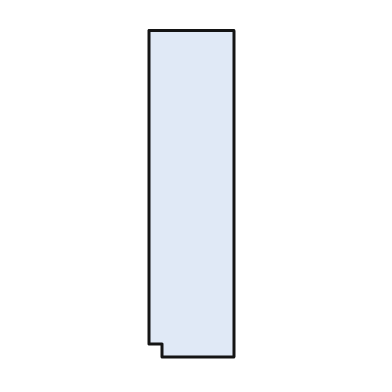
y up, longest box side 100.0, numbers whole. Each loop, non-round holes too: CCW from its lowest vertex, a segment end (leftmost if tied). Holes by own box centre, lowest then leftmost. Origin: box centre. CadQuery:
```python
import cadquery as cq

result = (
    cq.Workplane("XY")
    .moveTo(-9.0, -50.0)
    .lineTo(13.0, -50.0)
    .lineTo(13.0, 50.0)
    .lineTo(-13.0, 50.0)
    .lineTo(-13.0, -46.0)
    .lineTo(-9.0, -46.0)
    .close()
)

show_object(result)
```